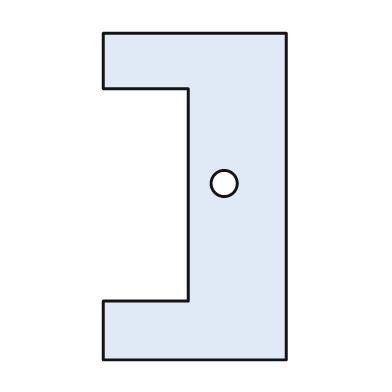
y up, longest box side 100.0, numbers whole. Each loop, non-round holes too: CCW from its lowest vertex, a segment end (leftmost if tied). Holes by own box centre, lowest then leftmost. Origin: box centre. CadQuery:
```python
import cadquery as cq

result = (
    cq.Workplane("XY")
    .moveTo(-28.0, -50.0)
    .lineTo(28.0, -50.0)
    .lineTo(28.0, 50.0)
    .lineTo(-28.0, 50.0)
    .lineTo(-28.0, 33.0)
    .lineTo(-2.0, 33.0)
    .lineTo(-2.0, -32.0)
    .lineTo(-28.0, -32.0)
    .close()
    .moveTo(9.0, 4.0)
    .circle(4.0)
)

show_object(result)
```